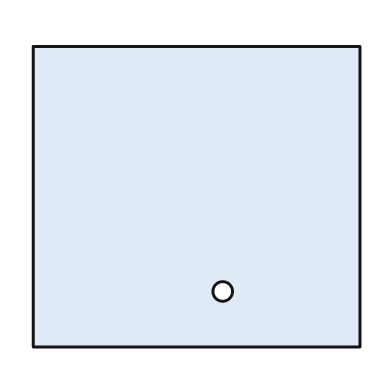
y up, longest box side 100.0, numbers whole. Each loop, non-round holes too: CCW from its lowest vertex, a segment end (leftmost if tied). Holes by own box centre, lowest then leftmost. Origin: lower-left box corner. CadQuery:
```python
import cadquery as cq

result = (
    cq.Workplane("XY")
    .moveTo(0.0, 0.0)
    .lineTo(100.0, 0.0)
    .lineTo(100.0, 92.0)
    .lineTo(0.0, 92.0)
    .close()
    .moveTo(58.0, 17.0)
    .circle(3.0)
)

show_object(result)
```